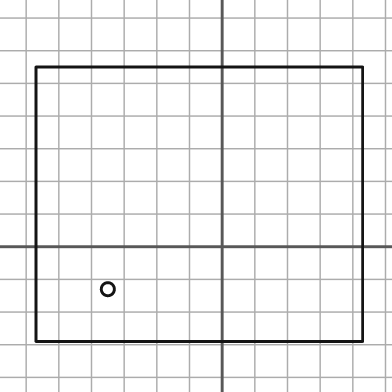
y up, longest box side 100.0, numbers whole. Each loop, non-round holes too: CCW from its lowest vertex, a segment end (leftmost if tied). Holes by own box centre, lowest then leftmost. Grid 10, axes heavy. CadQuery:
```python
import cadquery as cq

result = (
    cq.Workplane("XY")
    .moveTo(-57.0, -29.0)
    .lineTo(43.0, -29.0)
    .lineTo(43.0, 55.0)
    .lineTo(-57.0, 55.0)
    .close()
    .moveTo(-35.0, -13.0)
    .circle(2.0)
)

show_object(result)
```